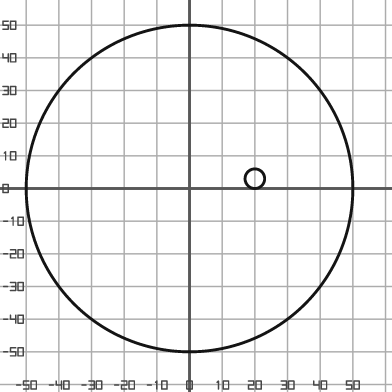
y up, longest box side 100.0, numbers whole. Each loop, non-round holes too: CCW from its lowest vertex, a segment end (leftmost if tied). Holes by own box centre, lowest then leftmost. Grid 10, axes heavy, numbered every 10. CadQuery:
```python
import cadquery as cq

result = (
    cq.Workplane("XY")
    .moveTo(0.0, 0.0)
    .circle(50.0)
    .moveTo(20.0, 3.0)
    .circle(3.0)
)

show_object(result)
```